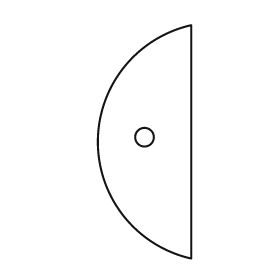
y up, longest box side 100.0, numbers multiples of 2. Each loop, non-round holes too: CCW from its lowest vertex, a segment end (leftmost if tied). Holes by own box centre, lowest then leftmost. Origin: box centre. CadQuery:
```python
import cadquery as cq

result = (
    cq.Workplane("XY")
    .moveTo(20.0, -50.0)
    .lineTo(20.0, 50.0)
    .threePointArc((-20.0, 0.0), (20.0, -50.0))
    .close()
    .moveTo(0.0, 2.0)
    .circle(4.0)
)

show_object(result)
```